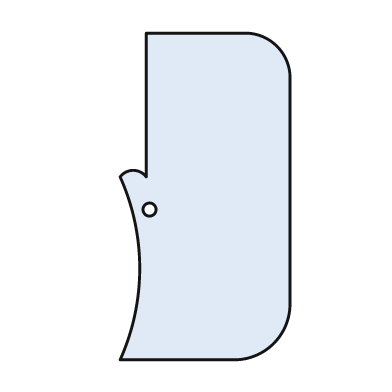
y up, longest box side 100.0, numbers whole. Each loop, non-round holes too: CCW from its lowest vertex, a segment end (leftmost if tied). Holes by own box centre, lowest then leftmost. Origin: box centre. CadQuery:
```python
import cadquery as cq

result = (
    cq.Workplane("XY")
    .moveTo(-26.0, -50.0)
    .lineTo(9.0, -50.0)
    .threePointArc((21.0, -45.0), (26.0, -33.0))
    .lineTo(26.0, 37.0)
    .threePointArc((22.0, 46.0), (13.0, 50.0))
    .lineTo(-18.0, 50.0)
    .lineTo(-18.0, 6.0)
    .threePointArc((-22.0, 8.0), (-26.0, 6.0))
    .threePointArc((-20.0, -22.0), (-26.0, -50.0))
    .close()
    .moveTo(-17.0, -4.0)
    .circle(2.0)
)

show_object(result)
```